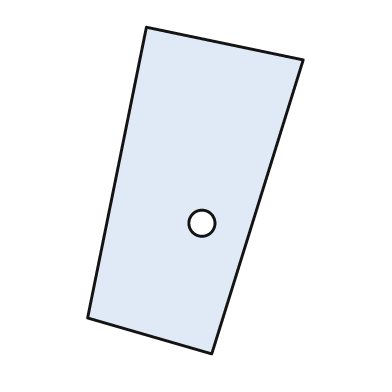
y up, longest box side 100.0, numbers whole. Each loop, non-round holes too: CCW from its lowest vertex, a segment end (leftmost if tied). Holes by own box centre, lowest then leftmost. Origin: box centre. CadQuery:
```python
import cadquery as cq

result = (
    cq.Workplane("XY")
    .moveTo(5.0, -50.0)
    .lineTo(33.0, 40.0)
    .lineTo(-15.0, 50.0)
    .lineTo(-33.0, -39.0)
    .close()
    .moveTo(2.0, -10.0)
    .circle(4.0)
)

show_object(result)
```